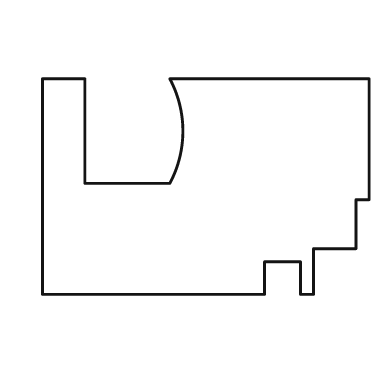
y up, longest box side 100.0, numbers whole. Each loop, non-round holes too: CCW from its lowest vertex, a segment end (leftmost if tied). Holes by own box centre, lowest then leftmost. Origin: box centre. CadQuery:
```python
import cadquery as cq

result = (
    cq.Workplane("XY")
    .moveTo(-50.0, -33.0)
    .lineTo(18.0, -33.0)
    .lineTo(18.0, -23.0)
    .lineTo(29.0, -23.0)
    .lineTo(29.0, -33.0)
    .lineTo(33.0, -33.0)
    .lineTo(33.0, -19.0)
    .lineTo(46.0, -19.0)
    .lineTo(46.0, -4.0)
    .lineTo(50.0, -4.0)
    .lineTo(50.0, 33.0)
    .lineTo(-11.0, 33.0)
    .threePointArc((-7.0, 17.0), (-11.0, 1.0))
    .lineTo(-37.0, 1.0)
    .lineTo(-37.0, 33.0)
    .lineTo(-50.0, 33.0)
    .close()
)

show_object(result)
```